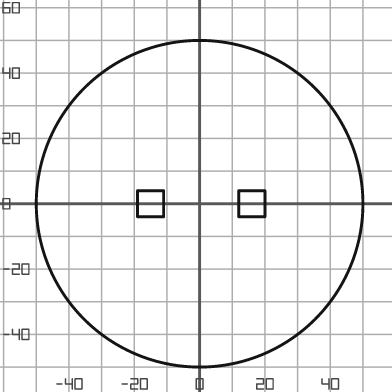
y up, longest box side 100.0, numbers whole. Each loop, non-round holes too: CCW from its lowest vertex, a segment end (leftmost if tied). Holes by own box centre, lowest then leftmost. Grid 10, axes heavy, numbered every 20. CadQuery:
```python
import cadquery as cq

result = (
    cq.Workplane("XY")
    .moveTo(0.0, 0.0)
    .circle(50.0)
    .moveTo(-19.0, -4.0)
    .lineTo(-11.0, -4.0)
    .lineTo(-11.0, 4.0)
    .lineTo(-19.0, 4.0)
    .close()
    .moveTo(12.0, -4.0)
    .lineTo(20.0, -4.0)
    .lineTo(20.0, 4.0)
    .lineTo(12.0, 4.0)
    .close()
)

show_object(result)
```